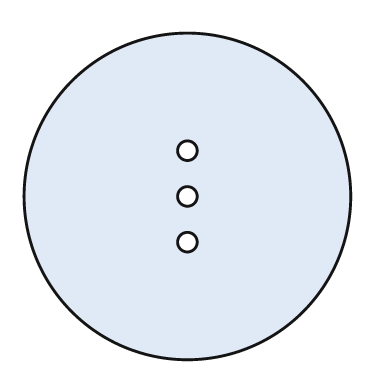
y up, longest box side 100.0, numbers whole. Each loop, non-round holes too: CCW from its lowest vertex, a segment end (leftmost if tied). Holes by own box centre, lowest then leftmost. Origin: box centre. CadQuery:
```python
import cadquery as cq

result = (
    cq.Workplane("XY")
    .moveTo(0.0, 0.0)
    .circle(50.0)
    .moveTo(0.0, -14.0)
    .circle(3.0)
    .moveTo(0.0, 0.0)
    .circle(3.0)
    .moveTo(0.0, 14.0)
    .circle(3.0)
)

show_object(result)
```